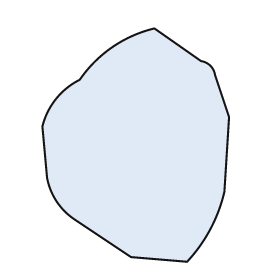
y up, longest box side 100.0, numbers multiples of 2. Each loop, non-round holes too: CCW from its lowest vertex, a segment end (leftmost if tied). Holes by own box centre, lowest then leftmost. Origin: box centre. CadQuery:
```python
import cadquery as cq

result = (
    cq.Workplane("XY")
    .moveTo(22.0, -50.0)
    .threePointArc((32.0, -36.0), (38.0, -20.0))
    .lineTo(40.0, 12.0)
    .lineTo(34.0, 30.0)
    .threePointArc((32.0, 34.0), (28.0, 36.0))
    .lineTo(8.0, 50.0)
    .threePointArc((-10.0, 42.0), (-24.0, 28.0))
    .threePointArc((-34.0, 20.0), (-40.0, 8.0))
    .lineTo(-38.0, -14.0)
    .threePointArc((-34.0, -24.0), (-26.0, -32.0))
    .lineTo(-2.0, -48.0)
    .close()
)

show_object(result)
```